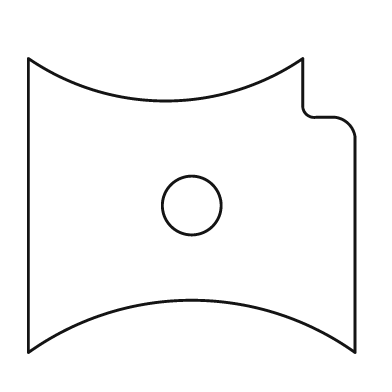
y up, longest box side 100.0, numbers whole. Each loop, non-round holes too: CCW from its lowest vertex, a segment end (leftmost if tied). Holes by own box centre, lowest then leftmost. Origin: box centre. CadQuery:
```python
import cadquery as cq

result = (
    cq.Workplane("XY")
    .moveTo(-50.0, -45.0)
    .threePointArc((0.0, -29.0), (50.0, -45.0))
    .lineTo(50.0, 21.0)
    .threePointArc((48.0, 25.0), (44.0, 27.0))
    .lineTo(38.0, 27.0)
    .threePointArc((35.0, 28.0), (34.0, 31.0))
    .lineTo(34.0, 45.0)
    .threePointArc((-8.0, 32.0), (-50.0, 45.0))
    .close()
    .moveTo(0.0, 0.0)
    .circle(9.0)
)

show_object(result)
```